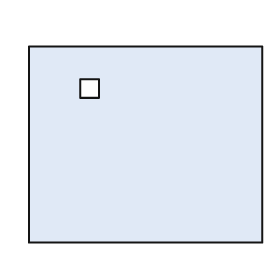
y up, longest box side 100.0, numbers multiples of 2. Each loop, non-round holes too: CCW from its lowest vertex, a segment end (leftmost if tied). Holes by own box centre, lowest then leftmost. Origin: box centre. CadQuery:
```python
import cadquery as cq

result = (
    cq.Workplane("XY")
    .moveTo(-50.0, -42.0)
    .lineTo(50.0, -42.0)
    .lineTo(50.0, 42.0)
    .lineTo(-50.0, 42.0)
    .close()
    .moveTo(-28.0, 20.0)
    .lineTo(-20.0, 20.0)
    .lineTo(-20.0, 28.0)
    .lineTo(-28.0, 28.0)
    .close()
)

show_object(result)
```